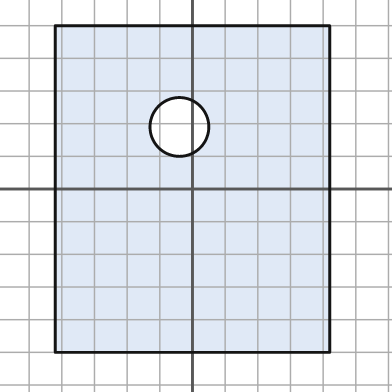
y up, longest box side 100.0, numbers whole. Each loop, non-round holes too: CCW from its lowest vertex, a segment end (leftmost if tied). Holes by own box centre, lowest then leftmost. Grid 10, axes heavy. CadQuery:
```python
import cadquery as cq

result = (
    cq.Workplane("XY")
    .moveTo(-42.0, -50.0)
    .lineTo(42.0, -50.0)
    .lineTo(42.0, 50.0)
    .lineTo(-42.0, 50.0)
    .close()
    .moveTo(-4.0, 19.0)
    .circle(9.0)
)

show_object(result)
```